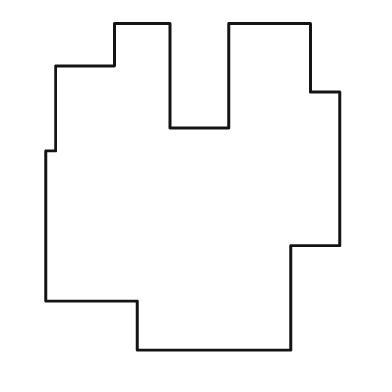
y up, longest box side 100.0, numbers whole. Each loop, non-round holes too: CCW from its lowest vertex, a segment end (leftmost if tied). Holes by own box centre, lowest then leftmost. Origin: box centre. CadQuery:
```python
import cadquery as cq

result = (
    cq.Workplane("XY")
    .moveTo(-17.0, -50.0)
    .lineTo(30.0, -50.0)
    .lineTo(30.0, -18.0)
    .lineTo(45.0, -18.0)
    .lineTo(45.0, 29.0)
    .lineTo(36.0, 29.0)
    .lineTo(36.0, 50.0)
    .lineTo(11.0, 50.0)
    .lineTo(11.0, 18.0)
    .lineTo(-7.0, 18.0)
    .lineTo(-7.0, 50.0)
    .lineTo(-24.0, 50.0)
    .lineTo(-24.0, 37.0)
    .lineTo(-42.0, 37.0)
    .lineTo(-42.0, 11.0)
    .lineTo(-45.0, 11.0)
    .lineTo(-45.0, -35.0)
    .lineTo(-17.0, -35.0)
    .close()
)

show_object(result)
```